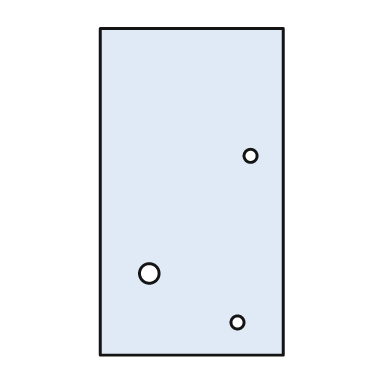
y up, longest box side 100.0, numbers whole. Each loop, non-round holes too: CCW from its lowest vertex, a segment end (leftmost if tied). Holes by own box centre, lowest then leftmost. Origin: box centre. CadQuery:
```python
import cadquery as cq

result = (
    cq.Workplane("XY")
    .moveTo(-28.0, -50.0)
    .lineTo(28.0, -50.0)
    .lineTo(28.0, 50.0)
    .lineTo(-28.0, 50.0)
    .close()
    .moveTo(14.0, -40.0)
    .circle(2.0)
    .moveTo(-13.0, -25.0)
    .circle(3.0)
    .moveTo(18.0, 11.0)
    .circle(2.0)
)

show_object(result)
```